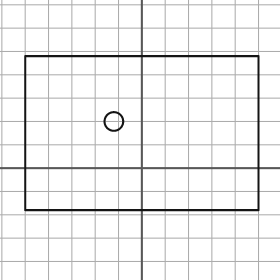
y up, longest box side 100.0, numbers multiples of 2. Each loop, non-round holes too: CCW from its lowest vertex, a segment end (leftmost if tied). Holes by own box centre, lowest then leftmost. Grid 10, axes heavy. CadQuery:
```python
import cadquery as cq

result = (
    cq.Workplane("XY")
    .moveTo(-50.0, -18.0)
    .lineTo(50.0, -18.0)
    .lineTo(50.0, 48.0)
    .lineTo(-50.0, 48.0)
    .close()
    .moveTo(-12.0, 20.0)
    .circle(4.0)
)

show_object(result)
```